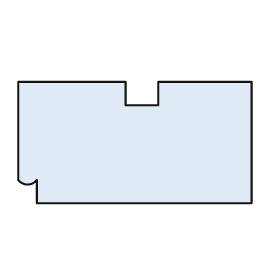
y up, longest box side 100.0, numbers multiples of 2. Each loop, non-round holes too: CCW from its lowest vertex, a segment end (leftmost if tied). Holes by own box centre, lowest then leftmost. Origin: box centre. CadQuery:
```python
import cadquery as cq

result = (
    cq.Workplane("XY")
    .moveTo(-42.0, -26.0)
    .lineTo(50.0, -26.0)
    .lineTo(50.0, 26.0)
    .lineTo(10.0, 26.0)
    .lineTo(10.0, 16.0)
    .lineTo(-4.0, 16.0)
    .lineTo(-4.0, 26.0)
    .lineTo(-50.0, 26.0)
    .lineTo(-50.0, -16.0)
    .threePointArc((-46.0, -18.0), (-42.0, -16.0))
    .close()
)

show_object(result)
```